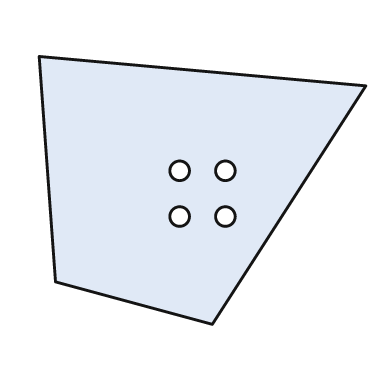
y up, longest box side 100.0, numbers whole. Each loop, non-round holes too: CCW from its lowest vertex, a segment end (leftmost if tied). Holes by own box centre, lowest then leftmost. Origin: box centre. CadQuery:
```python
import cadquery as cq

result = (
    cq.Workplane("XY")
    .moveTo(3.0, -41.0)
    .lineTo(50.0, 32.0)
    .lineTo(-50.0, 41.0)
    .lineTo(-45.0, -28.0)
    .close()
    .moveTo(-7.0, -8.0)
    .circle(3.0)
    .moveTo(7.0, -8.0)
    .circle(3.0)
    .moveTo(-7.0, 6.0)
    .circle(3.0)
    .moveTo(7.0, 6.0)
    .circle(3.0)
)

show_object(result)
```